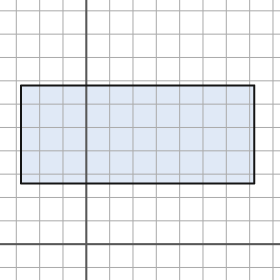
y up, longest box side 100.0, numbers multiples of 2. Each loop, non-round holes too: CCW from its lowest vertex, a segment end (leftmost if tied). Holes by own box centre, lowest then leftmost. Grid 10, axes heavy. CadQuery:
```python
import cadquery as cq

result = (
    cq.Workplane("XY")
    .moveTo(-28.0, 26.0)
    .lineTo(72.0, 26.0)
    .lineTo(72.0, 68.0)
    .lineTo(-28.0, 68.0)
    .close()
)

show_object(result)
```